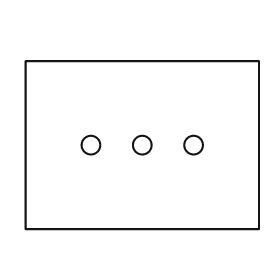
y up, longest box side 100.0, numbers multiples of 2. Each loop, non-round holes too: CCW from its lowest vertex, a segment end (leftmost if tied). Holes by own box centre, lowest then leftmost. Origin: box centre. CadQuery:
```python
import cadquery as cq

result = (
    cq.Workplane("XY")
    .moveTo(-50.0, -36.0)
    .lineTo(50.0, -36.0)
    .lineTo(50.0, 36.0)
    .lineTo(-50.0, 36.0)
    .close()
    .moveTo(-22.0, 0.0)
    .circle(4.0)
    .moveTo(0.0, 0.0)
    .circle(4.0)
    .moveTo(22.0, 0.0)
    .circle(4.0)
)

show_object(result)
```